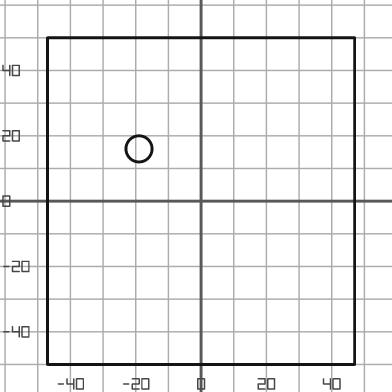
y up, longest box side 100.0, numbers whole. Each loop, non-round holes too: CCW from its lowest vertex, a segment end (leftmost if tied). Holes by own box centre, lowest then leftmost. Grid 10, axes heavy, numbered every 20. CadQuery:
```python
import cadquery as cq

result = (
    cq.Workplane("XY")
    .moveTo(-47.0, -50.0)
    .lineTo(47.0, -50.0)
    .lineTo(47.0, 50.0)
    .lineTo(-47.0, 50.0)
    .close()
    .moveTo(-19.0, 16.0)
    .circle(4.0)
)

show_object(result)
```